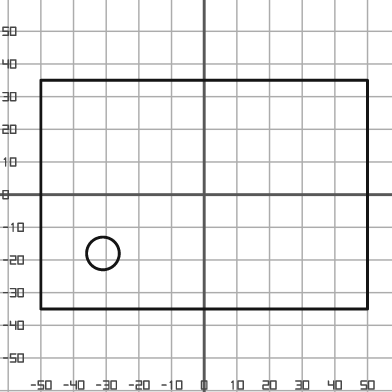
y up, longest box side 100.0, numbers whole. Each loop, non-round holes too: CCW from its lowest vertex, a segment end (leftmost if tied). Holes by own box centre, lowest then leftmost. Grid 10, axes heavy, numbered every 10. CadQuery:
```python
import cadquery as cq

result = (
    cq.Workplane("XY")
    .moveTo(-50.0, -35.0)
    .lineTo(50.0, -35.0)
    .lineTo(50.0, 35.0)
    .lineTo(-50.0, 35.0)
    .close()
    .moveTo(-31.0, -18.0)
    .circle(5.0)
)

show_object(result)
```